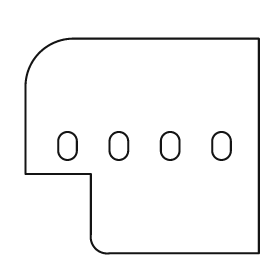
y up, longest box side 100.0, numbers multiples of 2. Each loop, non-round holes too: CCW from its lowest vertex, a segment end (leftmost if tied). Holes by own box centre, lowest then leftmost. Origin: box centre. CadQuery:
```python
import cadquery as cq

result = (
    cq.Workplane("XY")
    .moveTo(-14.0, -46.0)
    .lineTo(50.0, -46.0)
    .lineTo(50.0, 46.0)
    .lineTo(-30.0, 46.0)
    .threePointArc((-44.0, 40.0), (-50.0, 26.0))
    .lineTo(-50.0, -12.0)
    .lineTo(-22.0, -12.0)
    .lineTo(-22.0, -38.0)
    .threePointArc((-20.0, -44.0), (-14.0, -46.0))
    .close()
    .moveTo(-36.0, -2.0)
    .threePointArc((-32.0, -6.0), (-28.0, -2.0))
    .lineTo(-28.0, 2.0)
    .threePointArc((-32.0, 6.0), (-36.0, 2.0))
    .close()
    .moveTo(-14.0, -2.0)
    .threePointArc((-10.0, -6.0), (-6.0, -2.0))
    .lineTo(-6.0, 2.0)
    .threePointArc((-10.0, 6.0), (-14.0, 2.0))
    .close()
    .moveTo(8.0, -2.0)
    .threePointArc((12.0, -6.0), (16.0, -2.0))
    .lineTo(16.0, 2.0)
    .threePointArc((12.0, 6.0), (8.0, 2.0))
    .close()
    .moveTo(30.0, -2.0)
    .threePointArc((34.0, -6.0), (38.0, -2.0))
    .lineTo(38.0, 2.0)
    .threePointArc((34.0, 6.0), (30.0, 2.0))
    .close()
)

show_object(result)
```